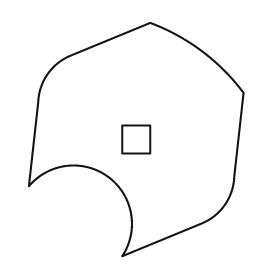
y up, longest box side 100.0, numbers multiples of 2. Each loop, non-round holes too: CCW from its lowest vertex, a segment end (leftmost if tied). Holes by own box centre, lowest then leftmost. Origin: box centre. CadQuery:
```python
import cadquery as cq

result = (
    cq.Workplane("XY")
    .moveTo(-6.0, -50.0)
    .lineTo(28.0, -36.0)
    .threePointArc((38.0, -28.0), (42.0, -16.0))
    .lineTo(46.0, 20.0)
    .threePointArc((28.0, 38.0), (6.0, 50.0))
    .lineTo(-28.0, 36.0)
    .threePointArc((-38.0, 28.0), (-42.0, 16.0))
    .lineTo(-46.0, -20.0)
    .threePointArc((-12.0, -16.0), (-6.0, -50.0))
    .close()
    .moveTo(-6.0, -6.0)
    .lineTo(6.0, -6.0)
    .lineTo(6.0, 6.0)
    .lineTo(-6.0, 6.0)
    .close()
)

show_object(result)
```